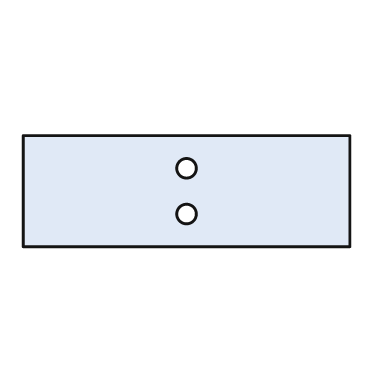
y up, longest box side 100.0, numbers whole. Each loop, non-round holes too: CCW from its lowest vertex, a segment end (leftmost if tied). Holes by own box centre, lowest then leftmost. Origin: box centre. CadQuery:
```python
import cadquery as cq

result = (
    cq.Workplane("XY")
    .moveTo(-50.0, -17.0)
    .lineTo(50.0, -17.0)
    .lineTo(50.0, 17.0)
    .lineTo(-50.0, 17.0)
    .close()
    .moveTo(0.0, -7.0)
    .circle(3.0)
    .moveTo(0.0, 7.0)
    .circle(3.0)
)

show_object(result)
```